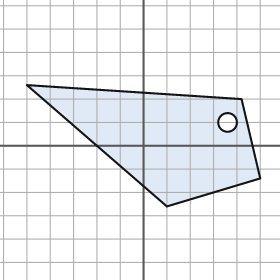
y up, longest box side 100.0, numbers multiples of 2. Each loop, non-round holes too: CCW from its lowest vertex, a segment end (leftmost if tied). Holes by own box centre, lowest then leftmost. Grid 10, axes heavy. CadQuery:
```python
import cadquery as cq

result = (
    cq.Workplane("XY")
    .moveTo(10.0, -26.0)
    .lineTo(50.0, -14.0)
    .lineTo(42.0, 20.0)
    .lineTo(-50.0, 26.0)
    .close()
    .moveTo(36.0, 10.0)
    .circle(4.0)
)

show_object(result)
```